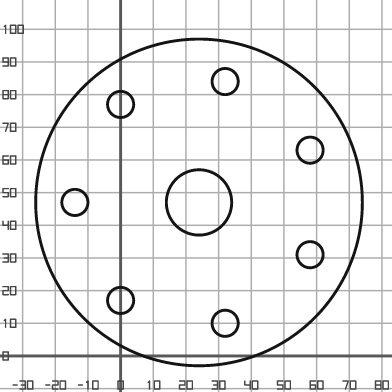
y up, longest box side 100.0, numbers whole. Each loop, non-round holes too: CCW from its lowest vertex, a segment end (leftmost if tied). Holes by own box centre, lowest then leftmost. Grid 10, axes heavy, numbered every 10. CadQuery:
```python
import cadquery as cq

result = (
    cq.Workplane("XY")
    .moveTo(24.0, 47.0)
    .circle(50.0)
    .moveTo(32.0, 10.0)
    .circle(4.0)
    .moveTo(0.0, 17.0)
    .circle(4.0)
    .moveTo(58.0, 31.0)
    .circle(4.0)
    .moveTo(-14.0, 47.0)
    .circle(4.0)
    .moveTo(24.0, 47.0)
    .circle(10.0)
    .moveTo(58.0, 63.0)
    .circle(4.0)
    .moveTo(0.0, 77.0)
    .circle(4.0)
    .moveTo(32.0, 84.0)
    .circle(4.0)
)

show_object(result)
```